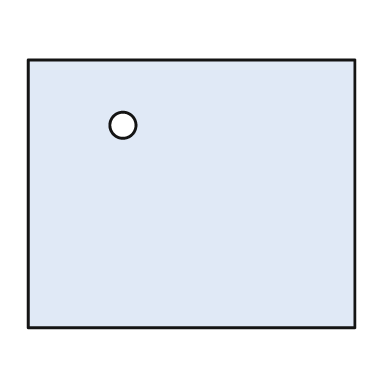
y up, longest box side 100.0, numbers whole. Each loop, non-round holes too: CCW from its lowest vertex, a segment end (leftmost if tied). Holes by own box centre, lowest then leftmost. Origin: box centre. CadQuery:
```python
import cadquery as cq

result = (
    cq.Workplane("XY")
    .moveTo(-50.0, -41.0)
    .lineTo(50.0, -41.0)
    .lineTo(50.0, 41.0)
    .lineTo(-50.0, 41.0)
    .close()
    .moveTo(-21.0, 21.0)
    .circle(4.0)
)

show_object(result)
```